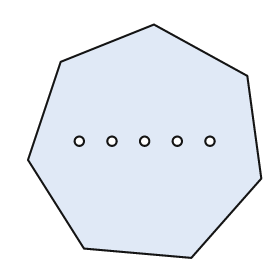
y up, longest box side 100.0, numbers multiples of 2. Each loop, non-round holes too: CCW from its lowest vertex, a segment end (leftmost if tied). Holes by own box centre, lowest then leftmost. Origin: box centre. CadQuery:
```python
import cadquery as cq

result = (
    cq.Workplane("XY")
    .moveTo(20.0, -50.0)
    .lineTo(50.0, -16.0)
    .lineTo(44.0, 28.0)
    .lineTo(4.0, 50.0)
    .lineTo(-36.0, 34.0)
    .lineTo(-50.0, -8.0)
    .lineTo(-26.0, -46.0)
    .close()
    .moveTo(-28.0, 0.0)
    .circle(2.0)
    .moveTo(-14.0, 0.0)
    .circle(2.0)
    .moveTo(0.0, 0.0)
    .circle(2.0)
    .moveTo(14.0, 0.0)
    .circle(2.0)
    .moveTo(28.0, 0.0)
    .circle(2.0)
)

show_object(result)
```